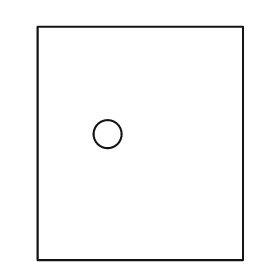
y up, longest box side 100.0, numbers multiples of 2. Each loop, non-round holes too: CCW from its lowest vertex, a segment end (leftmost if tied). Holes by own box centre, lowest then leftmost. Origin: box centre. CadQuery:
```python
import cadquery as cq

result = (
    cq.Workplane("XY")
    .moveTo(-44.0, -50.0)
    .lineTo(44.0, -50.0)
    .lineTo(44.0, 50.0)
    .lineTo(-44.0, 50.0)
    .close()
    .moveTo(-14.0, 4.0)
    .circle(6.0)
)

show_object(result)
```